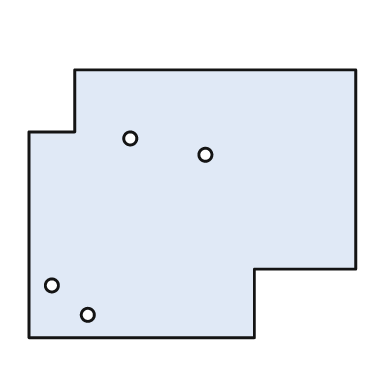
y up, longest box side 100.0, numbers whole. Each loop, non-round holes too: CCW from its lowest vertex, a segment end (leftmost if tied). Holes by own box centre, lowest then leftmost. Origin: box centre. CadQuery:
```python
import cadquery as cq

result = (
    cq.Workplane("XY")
    .moveTo(-50.0, -41.0)
    .lineTo(19.0, -41.0)
    .lineTo(19.0, -20.0)
    .lineTo(50.0, -20.0)
    .lineTo(50.0, 41.0)
    .lineTo(-36.0, 41.0)
    .lineTo(-36.0, 22.0)
    .lineTo(-50.0, 22.0)
    .close()
    .moveTo(-32.0, -34.0)
    .circle(2.0)
    .moveTo(-43.0, -25.0)
    .circle(2.0)
    .moveTo(4.0, 15.0)
    .circle(2.0)
    .moveTo(-19.0, 20.0)
    .circle(2.0)
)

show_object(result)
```